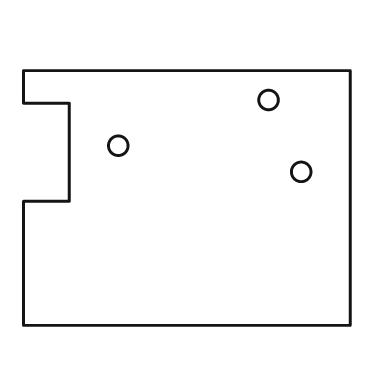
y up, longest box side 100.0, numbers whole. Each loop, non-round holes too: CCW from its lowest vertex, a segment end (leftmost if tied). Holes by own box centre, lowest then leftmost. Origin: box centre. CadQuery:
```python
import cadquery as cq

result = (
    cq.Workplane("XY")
    .moveTo(-50.0, -39.0)
    .lineTo(50.0, -39.0)
    .lineTo(50.0, 39.0)
    .lineTo(-50.0, 39.0)
    .lineTo(-50.0, 29.0)
    .lineTo(-36.0, 29.0)
    .lineTo(-36.0, -1.0)
    .lineTo(-50.0, -1.0)
    .close()
    .moveTo(35.0, 8.0)
    .circle(3.0)
    .moveTo(-21.0, 16.0)
    .circle(3.0)
    .moveTo(25.0, 30.0)
    .circle(3.0)
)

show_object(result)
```